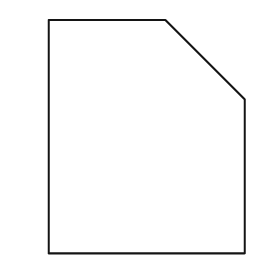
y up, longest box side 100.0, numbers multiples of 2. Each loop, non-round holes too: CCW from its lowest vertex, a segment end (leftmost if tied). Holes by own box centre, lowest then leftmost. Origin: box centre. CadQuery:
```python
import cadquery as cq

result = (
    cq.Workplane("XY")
    .moveTo(-42.0, -50.0)
    .lineTo(42.0, -50.0)
    .lineTo(42.0, 16.0)
    .lineTo(8.0, 50.0)
    .lineTo(-42.0, 50.0)
    .close()
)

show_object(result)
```